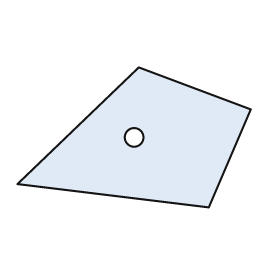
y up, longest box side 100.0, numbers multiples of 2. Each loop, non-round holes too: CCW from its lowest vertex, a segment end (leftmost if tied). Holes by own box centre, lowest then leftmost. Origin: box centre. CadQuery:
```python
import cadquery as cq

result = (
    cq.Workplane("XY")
    .moveTo(32.0, -30.0)
    .lineTo(50.0, 12.0)
    .lineTo(2.0, 30.0)
    .lineTo(-50.0, -20.0)
    .close()
    .moveTo(0.0, 0.0)
    .circle(4.0)
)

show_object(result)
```